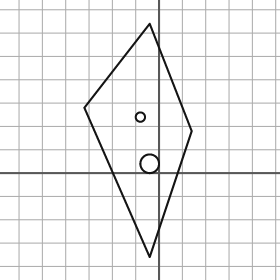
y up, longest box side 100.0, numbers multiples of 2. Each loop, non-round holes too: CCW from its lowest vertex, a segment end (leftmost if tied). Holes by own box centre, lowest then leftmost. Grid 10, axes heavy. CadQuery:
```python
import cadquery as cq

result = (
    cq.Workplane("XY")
    .moveTo(-4.0, -36.0)
    .lineTo(14.0, 18.0)
    .lineTo(-4.0, 64.0)
    .lineTo(-32.0, 28.0)
    .close()
    .moveTo(-4.0, 4.0)
    .circle(4.0)
    .moveTo(-8.0, 24.0)
    .circle(2.0)
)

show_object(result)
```